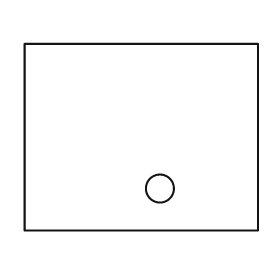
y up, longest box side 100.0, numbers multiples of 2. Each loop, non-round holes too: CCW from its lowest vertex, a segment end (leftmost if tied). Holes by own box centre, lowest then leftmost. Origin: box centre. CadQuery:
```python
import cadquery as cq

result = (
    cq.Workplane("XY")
    .moveTo(-50.0, -40.0)
    .lineTo(50.0, -40.0)
    .lineTo(50.0, 40.0)
    .lineTo(-50.0, 40.0)
    .close()
    .moveTo(8.0, -22.0)
    .circle(6.0)
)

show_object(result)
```